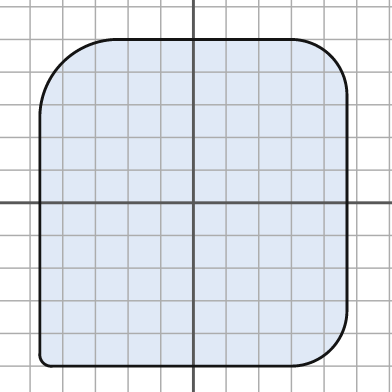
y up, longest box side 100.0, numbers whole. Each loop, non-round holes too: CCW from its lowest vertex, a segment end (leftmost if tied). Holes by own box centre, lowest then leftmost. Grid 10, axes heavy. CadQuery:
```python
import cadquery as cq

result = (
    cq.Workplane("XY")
    .moveTo(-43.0, -50.0)
    .lineTo(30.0, -50.0)
    .threePointArc((42.0, -45.0), (47.0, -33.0))
    .lineTo(47.0, 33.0)
    .threePointArc((42.0, 45.0), (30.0, 50.0))
    .lineTo(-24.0, 50.0)
    .threePointArc((-40.0, 43.0), (-47.0, 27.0))
    .lineTo(-47.0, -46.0)
    .threePointArc((-46.0, -49.0), (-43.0, -50.0))
    .close()
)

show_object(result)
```